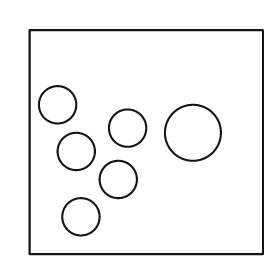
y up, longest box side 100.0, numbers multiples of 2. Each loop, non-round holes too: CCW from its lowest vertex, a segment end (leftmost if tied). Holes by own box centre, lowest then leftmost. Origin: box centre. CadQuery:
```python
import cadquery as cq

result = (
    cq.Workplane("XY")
    .moveTo(-50.0, -48.0)
    .lineTo(50.0, -48.0)
    .lineTo(50.0, 48.0)
    .lineTo(-50.0, 48.0)
    .close()
    .moveTo(-28.0, -32.0)
    .circle(8.0)
    .moveTo(-12.0, -16.0)
    .circle(8.0)
    .moveTo(-30.0, -4.0)
    .circle(8.0)
    .moveTo(20.0, 4.0)
    .circle(12.0)
    .moveTo(-8.0, 6.0)
    .circle(8.0)
    .moveTo(-38.0, 16.0)
    .circle(8.0)
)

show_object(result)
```